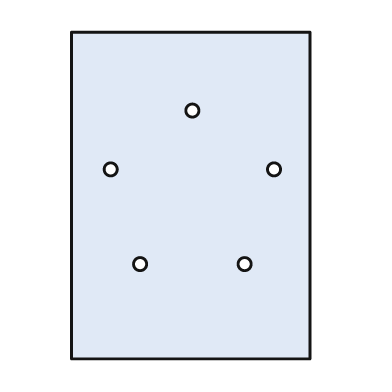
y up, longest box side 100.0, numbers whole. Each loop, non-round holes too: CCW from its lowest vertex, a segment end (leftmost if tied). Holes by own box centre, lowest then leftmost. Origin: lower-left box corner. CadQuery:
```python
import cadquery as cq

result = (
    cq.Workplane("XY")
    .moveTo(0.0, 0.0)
    .lineTo(73.0, 0.0)
    .lineTo(73.0, 100.0)
    .lineTo(0.0, 100.0)
    .close()
    .moveTo(21.0, 29.0)
    .circle(2.0)
    .moveTo(53.0, 29.0)
    .circle(2.0)
    .moveTo(12.0, 58.0)
    .circle(2.0)
    .moveTo(62.0, 58.0)
    .circle(2.0)
    .moveTo(37.0, 76.0)
    .circle(2.0)
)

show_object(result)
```